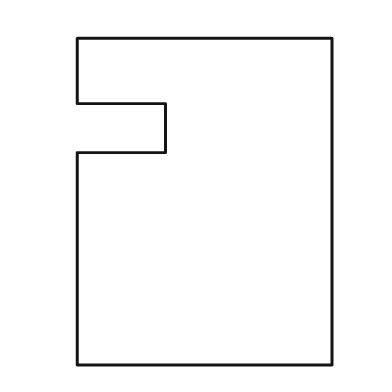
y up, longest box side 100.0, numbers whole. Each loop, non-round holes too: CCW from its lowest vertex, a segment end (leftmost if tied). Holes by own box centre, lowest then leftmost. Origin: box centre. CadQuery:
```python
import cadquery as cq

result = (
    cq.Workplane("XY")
    .moveTo(-39.0, -50.0)
    .lineTo(39.0, -50.0)
    .lineTo(39.0, 50.0)
    .lineTo(-39.0, 50.0)
    .lineTo(-39.0, 30.0)
    .lineTo(-12.0, 30.0)
    .lineTo(-12.0, 15.0)
    .lineTo(-39.0, 15.0)
    .close()
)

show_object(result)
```